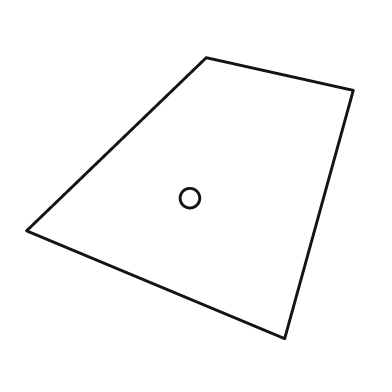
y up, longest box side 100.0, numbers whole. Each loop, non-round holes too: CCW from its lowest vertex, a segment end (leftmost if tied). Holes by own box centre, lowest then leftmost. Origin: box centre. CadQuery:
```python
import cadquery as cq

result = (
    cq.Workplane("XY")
    .moveTo(29.0, -43.0)
    .lineTo(50.0, 33.0)
    .lineTo(5.0, 43.0)
    .lineTo(-50.0, -10.0)
    .close()
    .moveTo(0.0, 0.0)
    .circle(3.0)
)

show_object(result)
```